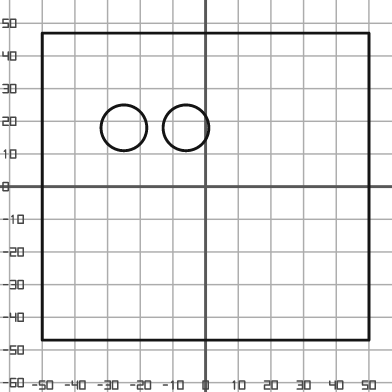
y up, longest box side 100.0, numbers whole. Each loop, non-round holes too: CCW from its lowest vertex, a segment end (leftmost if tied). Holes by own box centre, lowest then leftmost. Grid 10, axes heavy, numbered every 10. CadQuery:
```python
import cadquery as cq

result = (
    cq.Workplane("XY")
    .moveTo(-50.0, -47.0)
    .lineTo(50.0, -47.0)
    .lineTo(50.0, 47.0)
    .lineTo(-50.0, 47.0)
    .close()
    .moveTo(-25.0, 18.0)
    .circle(7.0)
    .moveTo(-6.0, 18.0)
    .circle(7.0)
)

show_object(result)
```